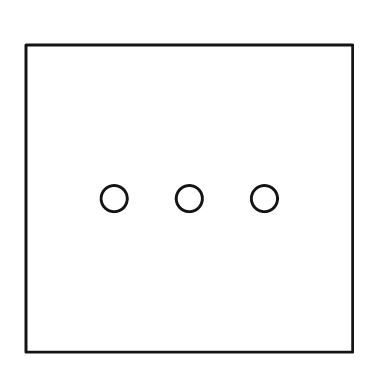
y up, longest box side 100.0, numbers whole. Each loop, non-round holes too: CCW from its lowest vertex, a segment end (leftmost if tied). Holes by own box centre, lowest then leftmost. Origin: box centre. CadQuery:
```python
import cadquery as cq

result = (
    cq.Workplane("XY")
    .moveTo(-50.0, -47.0)
    .lineTo(50.0, -47.0)
    .lineTo(50.0, 47.0)
    .lineTo(-50.0, 47.0)
    .close()
    .moveTo(-23.0, 0.0)
    .circle(4.0)
    .moveTo(0.0, 0.0)
    .circle(4.0)
    .moveTo(23.0, 0.0)
    .circle(4.0)
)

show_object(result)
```